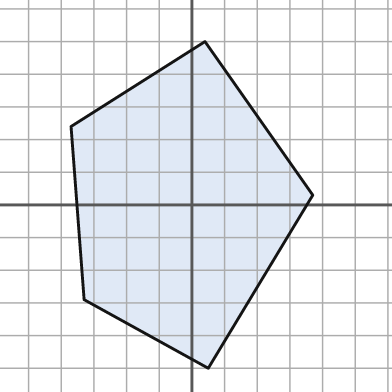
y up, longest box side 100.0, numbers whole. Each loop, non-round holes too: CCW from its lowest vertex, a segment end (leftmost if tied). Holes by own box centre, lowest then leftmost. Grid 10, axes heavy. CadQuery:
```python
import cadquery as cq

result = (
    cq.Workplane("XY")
    .moveTo(5.0, -50.0)
    .lineTo(37.0, 3.0)
    .lineTo(4.0, 50.0)
    .lineTo(-37.0, 24.0)
    .lineTo(-33.0, -29.0)
    .close()
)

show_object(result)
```